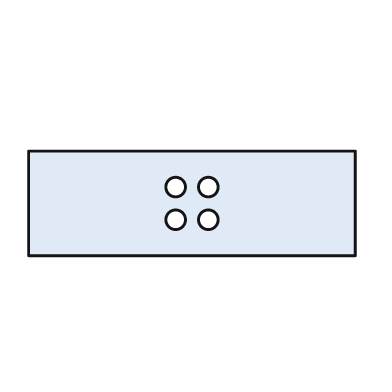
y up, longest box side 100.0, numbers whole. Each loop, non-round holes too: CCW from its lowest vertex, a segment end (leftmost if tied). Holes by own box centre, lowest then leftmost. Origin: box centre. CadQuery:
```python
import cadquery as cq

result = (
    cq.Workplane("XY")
    .moveTo(-50.0, -16.0)
    .lineTo(50.0, -16.0)
    .lineTo(50.0, 16.0)
    .lineTo(-50.0, 16.0)
    .close()
    .moveTo(-5.0, -5.0)
    .circle(3.0)
    .moveTo(5.0, -5.0)
    .circle(3.0)
    .moveTo(-5.0, 5.0)
    .circle(3.0)
    .moveTo(5.0, 5.0)
    .circle(3.0)
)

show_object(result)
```